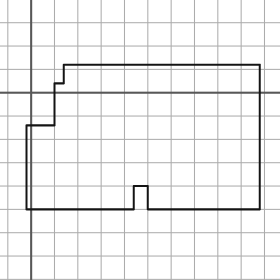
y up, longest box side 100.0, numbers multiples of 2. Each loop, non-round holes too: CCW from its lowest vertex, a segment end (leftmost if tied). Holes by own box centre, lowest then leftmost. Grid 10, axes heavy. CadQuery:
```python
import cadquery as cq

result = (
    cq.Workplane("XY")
    .moveTo(-2.0, -50.0)
    .lineTo(44.0, -50.0)
    .lineTo(44.0, -40.0)
    .lineTo(50.0, -40.0)
    .lineTo(50.0, -50.0)
    .lineTo(98.0, -50.0)
    .lineTo(98.0, 12.0)
    .lineTo(14.0, 12.0)
    .lineTo(14.0, 4.0)
    .lineTo(10.0, 4.0)
    .lineTo(10.0, -14.0)
    .lineTo(-2.0, -14.0)
    .close()
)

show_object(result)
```